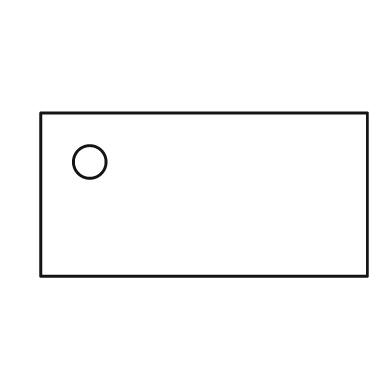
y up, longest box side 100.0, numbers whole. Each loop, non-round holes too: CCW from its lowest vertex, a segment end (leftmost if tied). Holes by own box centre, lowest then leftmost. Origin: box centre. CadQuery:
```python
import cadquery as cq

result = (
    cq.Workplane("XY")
    .moveTo(-50.0, -25.0)
    .lineTo(50.0, -25.0)
    .lineTo(50.0, 25.0)
    .lineTo(-50.0, 25.0)
    .close()
    .moveTo(-35.0, 10.0)
    .circle(5.0)
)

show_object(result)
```